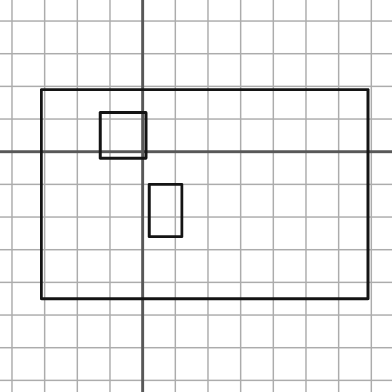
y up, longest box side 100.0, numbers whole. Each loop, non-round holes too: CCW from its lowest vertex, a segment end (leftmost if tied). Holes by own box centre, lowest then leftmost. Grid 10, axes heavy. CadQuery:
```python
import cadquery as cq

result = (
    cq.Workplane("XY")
    .moveTo(-31.0, -45.0)
    .lineTo(69.0, -45.0)
    .lineTo(69.0, 19.0)
    .lineTo(-31.0, 19.0)
    .close()
    .moveTo(2.0, -26.0)
    .lineTo(12.0, -26.0)
    .lineTo(12.0, -10.0)
    .lineTo(2.0, -10.0)
    .close()
    .moveTo(-13.0, -2.0)
    .lineTo(1.0, -2.0)
    .lineTo(1.0, 12.0)
    .lineTo(-13.0, 12.0)
    .close()
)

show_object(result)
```